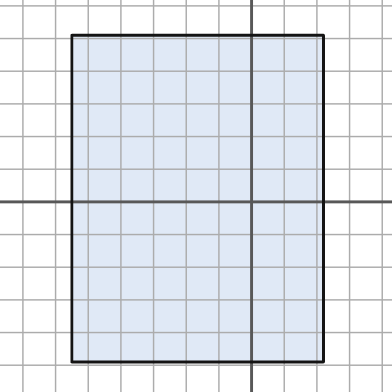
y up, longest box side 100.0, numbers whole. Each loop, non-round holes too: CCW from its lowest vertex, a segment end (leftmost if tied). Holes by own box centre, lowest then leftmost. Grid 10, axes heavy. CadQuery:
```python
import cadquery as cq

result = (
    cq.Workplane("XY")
    .moveTo(-55.0, -49.0)
    .lineTo(22.0, -49.0)
    .lineTo(22.0, 51.0)
    .lineTo(-55.0, 51.0)
    .close()
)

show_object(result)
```